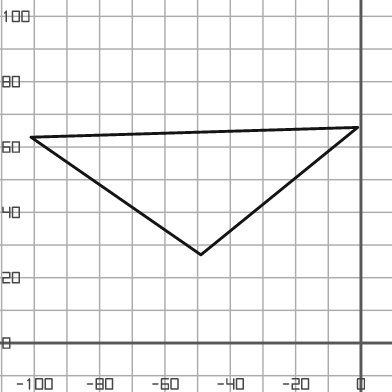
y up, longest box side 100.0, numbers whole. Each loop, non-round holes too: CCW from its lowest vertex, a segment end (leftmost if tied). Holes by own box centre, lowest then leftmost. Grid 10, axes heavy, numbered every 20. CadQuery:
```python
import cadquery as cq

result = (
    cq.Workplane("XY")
    .moveTo(-49.0, 27.0)
    .lineTo(-1.0, 66.0)
    .lineTo(-101.0, 63.0)
    .close()
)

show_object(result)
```